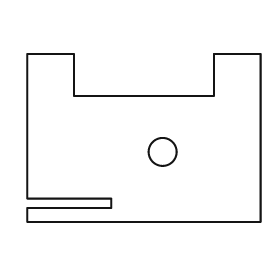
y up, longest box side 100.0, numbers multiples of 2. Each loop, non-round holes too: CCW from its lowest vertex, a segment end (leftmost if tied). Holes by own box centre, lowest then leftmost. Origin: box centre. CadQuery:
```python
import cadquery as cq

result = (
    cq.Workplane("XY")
    .moveTo(-50.0, -36.0)
    .lineTo(50.0, -36.0)
    .lineTo(50.0, 36.0)
    .lineTo(30.0, 36.0)
    .lineTo(30.0, 18.0)
    .lineTo(-30.0, 18.0)
    .lineTo(-30.0, 36.0)
    .lineTo(-50.0, 36.0)
    .lineTo(-50.0, -26.0)
    .lineTo(-14.0, -26.0)
    .lineTo(-14.0, -30.0)
    .lineTo(-50.0, -30.0)
    .close()
    .moveTo(8.0, -6.0)
    .circle(6.0)
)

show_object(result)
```